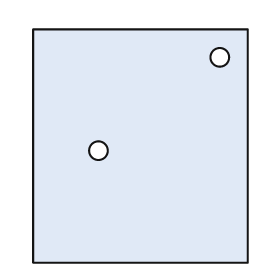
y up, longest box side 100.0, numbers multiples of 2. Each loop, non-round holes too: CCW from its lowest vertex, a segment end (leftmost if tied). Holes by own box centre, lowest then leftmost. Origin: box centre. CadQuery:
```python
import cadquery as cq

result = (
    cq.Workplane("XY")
    .moveTo(-46.0, -50.0)
    .lineTo(46.0, -50.0)
    .lineTo(46.0, 50.0)
    .lineTo(-46.0, 50.0)
    .close()
    .moveTo(-18.0, -2.0)
    .circle(4.0)
    .moveTo(34.0, 38.0)
    .circle(4.0)
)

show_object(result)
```